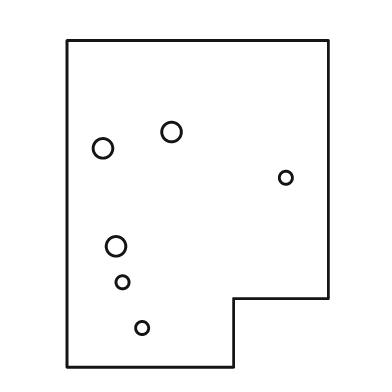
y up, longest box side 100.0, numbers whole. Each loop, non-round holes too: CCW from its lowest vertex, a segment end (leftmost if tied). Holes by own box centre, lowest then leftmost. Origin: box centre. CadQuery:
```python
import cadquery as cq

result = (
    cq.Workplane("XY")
    .moveTo(-40.0, -50.0)
    .lineTo(11.0, -50.0)
    .lineTo(11.0, -29.0)
    .lineTo(40.0, -29.0)
    .lineTo(40.0, 50.0)
    .lineTo(-40.0, 50.0)
    .close()
    .moveTo(-17.0, -38.0)
    .circle(2.0)
    .moveTo(-23.0, -24.0)
    .circle(2.0)
    .moveTo(-25.0, -13.0)
    .circle(3.0)
    .moveTo(27.0, 8.0)
    .circle(2.0)
    .moveTo(-29.0, 17.0)
    .circle(3.0)
    .moveTo(-8.0, 22.0)
    .circle(3.0)
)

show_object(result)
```